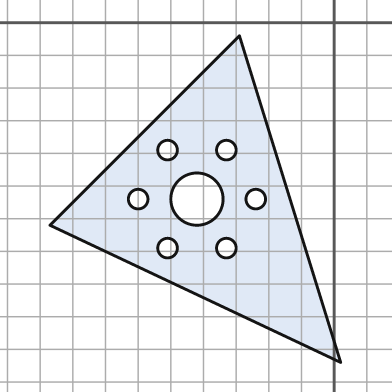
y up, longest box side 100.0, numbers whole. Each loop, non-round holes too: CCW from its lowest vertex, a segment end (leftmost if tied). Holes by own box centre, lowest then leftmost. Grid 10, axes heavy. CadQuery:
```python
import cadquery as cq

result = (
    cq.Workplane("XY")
    .moveTo(2.0, -104.0)
    .lineTo(-29.0, -4.0)
    .lineTo(-87.0, -62.0)
    .close()
    .moveTo(-51.0, -69.0)
    .circle(3.0)
    .moveTo(-33.0, -69.0)
    .circle(3.0)
    .moveTo(-60.0, -54.0)
    .circle(3.0)
    .moveTo(-42.0, -54.0)
    .circle(8.0)
    .moveTo(-24.0, -54.0)
    .circle(3.0)
    .moveTo(-51.0, -39.0)
    .circle(3.0)
    .moveTo(-33.0, -39.0)
    .circle(3.0)
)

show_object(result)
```